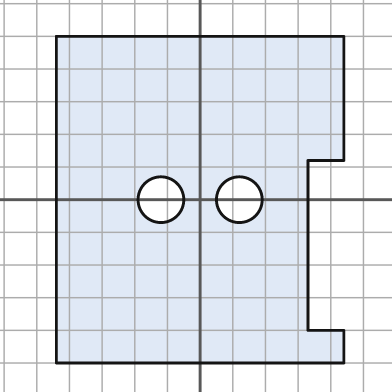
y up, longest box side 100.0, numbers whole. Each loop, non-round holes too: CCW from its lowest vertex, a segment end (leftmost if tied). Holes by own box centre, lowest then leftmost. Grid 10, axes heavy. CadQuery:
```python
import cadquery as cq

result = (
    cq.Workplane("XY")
    .moveTo(-44.0, -50.0)
    .lineTo(44.0, -50.0)
    .lineTo(44.0, -40.0)
    .lineTo(33.0, -40.0)
    .lineTo(33.0, 12.0)
    .lineTo(44.0, 12.0)
    .lineTo(44.0, 50.0)
    .lineTo(-44.0, 50.0)
    .close()
    .moveTo(-12.0, 0.0)
    .circle(7.0)
    .moveTo(12.0, 0.0)
    .circle(7.0)
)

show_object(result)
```